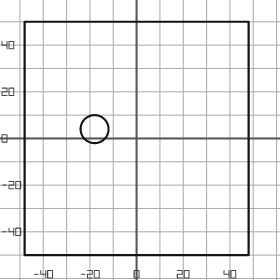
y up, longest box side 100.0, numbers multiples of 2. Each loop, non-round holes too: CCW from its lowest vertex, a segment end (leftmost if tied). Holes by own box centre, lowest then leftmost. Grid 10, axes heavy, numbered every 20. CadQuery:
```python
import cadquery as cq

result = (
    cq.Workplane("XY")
    .moveTo(-48.0, -50.0)
    .lineTo(48.0, -50.0)
    .lineTo(48.0, 50.0)
    .lineTo(-48.0, 50.0)
    .close()
    .moveTo(-18.0, 4.0)
    .circle(6.0)
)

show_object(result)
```